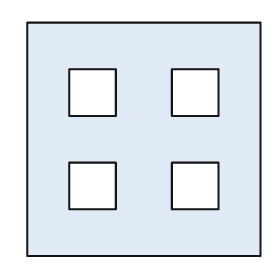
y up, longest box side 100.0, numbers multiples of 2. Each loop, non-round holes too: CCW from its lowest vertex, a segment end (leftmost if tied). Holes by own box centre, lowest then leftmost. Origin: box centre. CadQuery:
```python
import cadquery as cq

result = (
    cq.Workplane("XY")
    .moveTo(-50.0, -50.0)
    .lineTo(50.0, -50.0)
    .lineTo(50.0, 50.0)
    .lineTo(-50.0, 50.0)
    .close()
    .moveTo(-32.0, -30.0)
    .lineTo(-12.0, -30.0)
    .lineTo(-12.0, -10.0)
    .lineTo(-32.0, -10.0)
    .close()
    .moveTo(12.0, -30.0)
    .lineTo(32.0, -30.0)
    .lineTo(32.0, -10.0)
    .lineTo(12.0, -10.0)
    .close()
    .moveTo(-32.0, 10.0)
    .lineTo(-12.0, 10.0)
    .lineTo(-12.0, 30.0)
    .lineTo(-32.0, 30.0)
    .close()
    .moveTo(12.0, 10.0)
    .lineTo(32.0, 10.0)
    .lineTo(32.0, 30.0)
    .lineTo(12.0, 30.0)
    .close()
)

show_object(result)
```